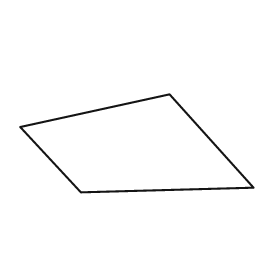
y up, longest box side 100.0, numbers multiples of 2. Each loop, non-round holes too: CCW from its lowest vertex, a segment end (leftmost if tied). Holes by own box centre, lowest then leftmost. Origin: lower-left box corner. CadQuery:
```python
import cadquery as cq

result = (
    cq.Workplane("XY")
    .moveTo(26.0, 0.0)
    .lineTo(100.0, 2.0)
    .lineTo(64.0, 42.0)
    .lineTo(0.0, 28.0)
    .close()
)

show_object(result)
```